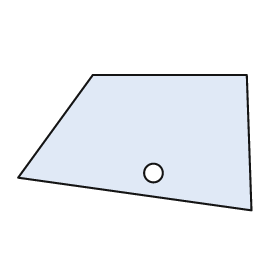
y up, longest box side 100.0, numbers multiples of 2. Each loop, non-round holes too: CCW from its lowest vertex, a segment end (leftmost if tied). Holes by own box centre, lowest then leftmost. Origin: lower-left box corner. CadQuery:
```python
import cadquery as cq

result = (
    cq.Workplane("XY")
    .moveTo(100.0, 0.0)
    .lineTo(98.0, 58.0)
    .lineTo(32.0, 58.0)
    .lineTo(0.0, 14.0)
    .close()
    .moveTo(58.0, 16.0)
    .circle(4.0)
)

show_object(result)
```